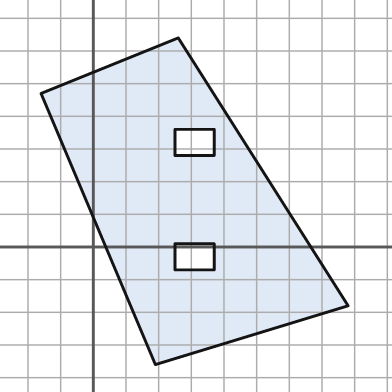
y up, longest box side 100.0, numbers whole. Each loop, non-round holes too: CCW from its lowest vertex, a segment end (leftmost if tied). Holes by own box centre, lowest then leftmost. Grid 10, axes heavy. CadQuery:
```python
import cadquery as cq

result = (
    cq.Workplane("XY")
    .moveTo(19.0, -36.0)
    .lineTo(78.0, -18.0)
    .lineTo(26.0, 64.0)
    .lineTo(-16.0, 47.0)
    .close()
    .moveTo(25.0, -7.0)
    .lineTo(37.0, -7.0)
    .lineTo(37.0, 1.0)
    .lineTo(25.0, 1.0)
    .close()
    .moveTo(25.0, 28.0)
    .lineTo(37.0, 28.0)
    .lineTo(37.0, 36.0)
    .lineTo(25.0, 36.0)
    .close()
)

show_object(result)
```